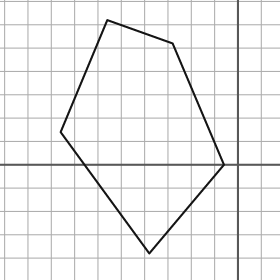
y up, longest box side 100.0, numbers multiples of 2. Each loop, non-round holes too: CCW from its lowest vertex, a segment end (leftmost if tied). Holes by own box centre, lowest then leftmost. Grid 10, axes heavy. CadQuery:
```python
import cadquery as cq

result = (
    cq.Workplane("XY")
    .moveTo(-38.0, -38.0)
    .lineTo(-6.0, 0.0)
    .lineTo(-28.0, 52.0)
    .lineTo(-56.0, 62.0)
    .lineTo(-76.0, 14.0)
    .close()
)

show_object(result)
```